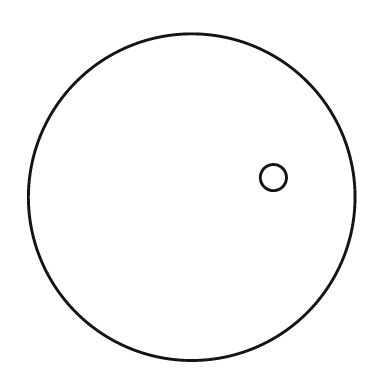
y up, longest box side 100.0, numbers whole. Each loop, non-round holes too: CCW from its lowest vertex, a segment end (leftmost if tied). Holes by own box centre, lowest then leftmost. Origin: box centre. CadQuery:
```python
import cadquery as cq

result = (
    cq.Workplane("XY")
    .moveTo(0.0, 0.0)
    .circle(50.0)
    .moveTo(25.0, 6.0)
    .circle(4.0)
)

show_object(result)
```